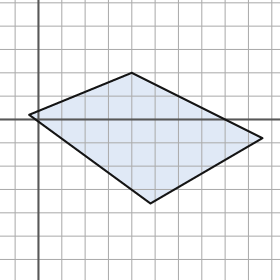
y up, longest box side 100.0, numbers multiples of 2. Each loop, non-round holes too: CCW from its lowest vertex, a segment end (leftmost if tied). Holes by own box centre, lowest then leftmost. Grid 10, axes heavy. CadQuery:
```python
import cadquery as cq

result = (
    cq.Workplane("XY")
    .moveTo(48.0, -36.0)
    .lineTo(96.0, -8.0)
    .lineTo(40.0, 20.0)
    .lineTo(-4.0, 2.0)
    .close()
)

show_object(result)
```